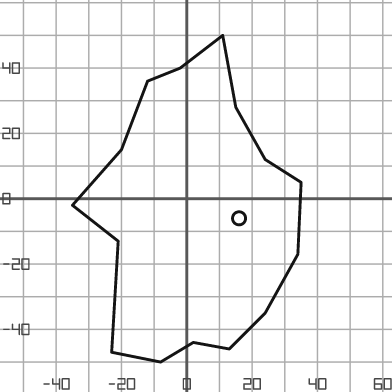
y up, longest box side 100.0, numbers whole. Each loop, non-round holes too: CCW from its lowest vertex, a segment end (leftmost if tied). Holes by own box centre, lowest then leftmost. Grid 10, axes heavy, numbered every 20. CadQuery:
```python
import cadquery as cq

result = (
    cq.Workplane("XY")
    .moveTo(-8.0, -50.0)
    .lineTo(2.0, -44.0)
    .lineTo(13.0, -46.0)
    .lineTo(24.0, -35.0)
    .lineTo(34.0, -17.0)
    .lineTo(35.0, 5.0)
    .lineTo(24.0, 12.0)
    .lineTo(15.0, 28.0)
    .lineTo(11.0, 50.0)
    .lineTo(-2.0, 40.0)
    .lineTo(-12.0, 36.0)
    .lineTo(-20.0, 15.0)
    .lineTo(-35.0, -2.0)
    .lineTo(-21.0, -13.0)
    .lineTo(-23.0, -47.0)
    .close()
    .moveTo(16.0, -6.0)
    .circle(2.0)
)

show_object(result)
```